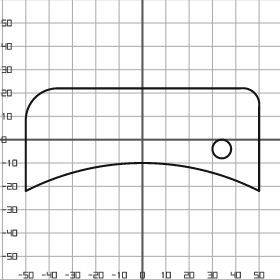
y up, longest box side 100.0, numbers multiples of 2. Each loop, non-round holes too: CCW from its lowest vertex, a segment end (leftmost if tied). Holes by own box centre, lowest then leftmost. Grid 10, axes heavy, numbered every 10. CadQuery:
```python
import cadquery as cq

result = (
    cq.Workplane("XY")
    .moveTo(-50.0, -22.0)
    .threePointArc((0.0, -10.0), (50.0, -22.0))
    .lineTo(50.0, 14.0)
    .threePointArc((48.0, 20.0), (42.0, 22.0))
    .lineTo(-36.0, 22.0)
    .threePointArc((-46.0, 18.0), (-50.0, 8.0))
    .close()
    .moveTo(34.0, -4.0)
    .circle(4.0)
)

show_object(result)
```